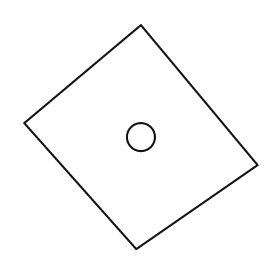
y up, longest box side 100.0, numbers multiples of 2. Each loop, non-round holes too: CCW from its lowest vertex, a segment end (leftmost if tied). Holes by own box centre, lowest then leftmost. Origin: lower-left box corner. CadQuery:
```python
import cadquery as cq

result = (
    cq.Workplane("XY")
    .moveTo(48.0, 0.0)
    .lineTo(100.0, 36.0)
    .lineTo(50.0, 96.0)
    .lineTo(0.0, 54.0)
    .close()
    .moveTo(50.0, 48.0)
    .circle(6.0)
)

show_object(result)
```